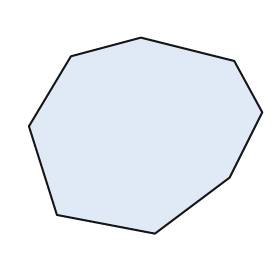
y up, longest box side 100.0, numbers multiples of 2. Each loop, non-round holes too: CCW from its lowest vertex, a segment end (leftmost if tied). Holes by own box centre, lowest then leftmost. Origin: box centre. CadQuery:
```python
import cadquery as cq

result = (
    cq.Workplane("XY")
    .moveTo(4.0, -42.0)
    .lineTo(36.0, -18.0)
    .lineTo(50.0, 10.0)
    .lineTo(38.0, 32.0)
    .lineTo(-2.0, 42.0)
    .lineTo(-32.0, 34.0)
    .lineTo(-50.0, 4.0)
    .lineTo(-38.0, -34.0)
    .close()
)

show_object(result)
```